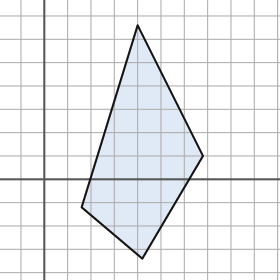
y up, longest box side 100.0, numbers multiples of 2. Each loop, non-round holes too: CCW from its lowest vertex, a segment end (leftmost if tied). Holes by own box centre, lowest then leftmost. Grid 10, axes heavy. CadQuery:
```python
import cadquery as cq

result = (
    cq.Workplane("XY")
    .moveTo(42.0, -34.0)
    .lineTo(68.0, 10.0)
    .lineTo(40.0, 66.0)
    .lineTo(16.0, -12.0)
    .close()
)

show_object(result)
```